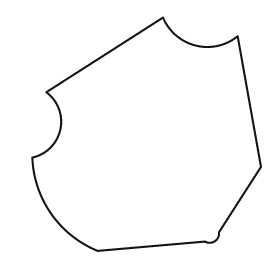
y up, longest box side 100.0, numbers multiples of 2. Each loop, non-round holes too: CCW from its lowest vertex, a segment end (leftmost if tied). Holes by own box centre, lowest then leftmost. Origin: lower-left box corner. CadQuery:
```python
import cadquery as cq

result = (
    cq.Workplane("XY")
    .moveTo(28.0, 0.0)
    .lineTo(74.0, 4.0)
    .threePointArc((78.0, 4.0), (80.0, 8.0))
    .lineTo(98.0, 36.0)
    .lineTo(88.0, 92.0)
    .threePointArc((70.0, 88.0), (56.0, 100.0))
    .lineTo(6.0, 68.0)
    .threePointArc((12.0, 52.0), (0.0, 40.0))
    .threePointArc((8.0, 16.0), (28.0, 0.0))
    .close()
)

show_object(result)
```